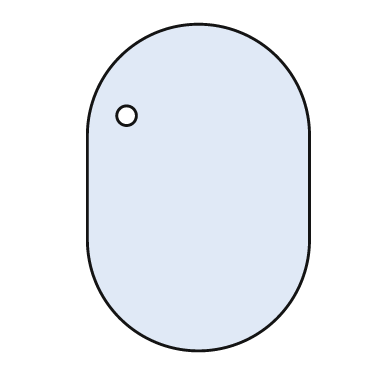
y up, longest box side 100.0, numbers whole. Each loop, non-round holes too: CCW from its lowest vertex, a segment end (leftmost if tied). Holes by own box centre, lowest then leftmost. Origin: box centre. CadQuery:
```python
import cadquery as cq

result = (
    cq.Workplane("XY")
    .moveTo(-34.0, -16.0)
    .threePointArc((0.0, -50.0), (34.0, -16.0))
    .lineTo(34.0, 16.0)
    .threePointArc((0.0, 50.0), (-34.0, 16.0))
    .close()
    .moveTo(-22.0, 22.0)
    .circle(3.0)
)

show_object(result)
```